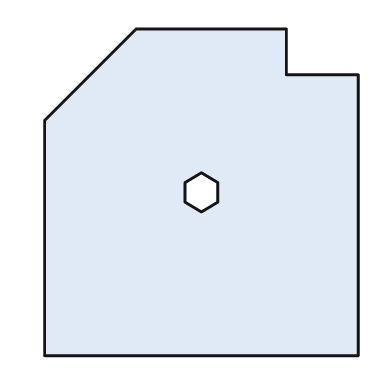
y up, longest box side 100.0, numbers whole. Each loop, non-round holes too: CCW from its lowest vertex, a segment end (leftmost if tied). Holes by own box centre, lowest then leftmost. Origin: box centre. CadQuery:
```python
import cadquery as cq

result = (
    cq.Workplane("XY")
    .moveTo(-48.0, -50.0)
    .lineTo(48.0, -50.0)
    .lineTo(48.0, 36.0)
    .lineTo(26.0, 36.0)
    .lineTo(26.0, 50.0)
    .lineTo(-20.0, 50.0)
    .lineTo(-48.0, 22.0)
    .close()
    .moveTo(0.0, -6.0)
    .lineTo(5.0, -3.0)
    .lineTo(5.0, 3.0)
    .lineTo(0.0, 6.0)
    .lineTo(-5.0, 3.0)
    .lineTo(-5.0, -3.0)
    .close()
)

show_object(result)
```